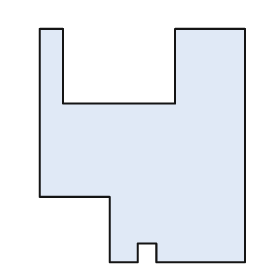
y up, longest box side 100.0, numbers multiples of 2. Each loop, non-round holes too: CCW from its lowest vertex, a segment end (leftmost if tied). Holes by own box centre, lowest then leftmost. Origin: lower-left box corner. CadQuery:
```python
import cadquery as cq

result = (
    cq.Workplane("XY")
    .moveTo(30.0, 0.0)
    .lineTo(42.0, 0.0)
    .lineTo(42.0, 8.0)
    .lineTo(50.0, 8.0)
    .lineTo(50.0, 0.0)
    .lineTo(88.0, 0.0)
    .lineTo(88.0, 100.0)
    .lineTo(58.0, 100.0)
    .lineTo(58.0, 68.0)
    .lineTo(10.0, 68.0)
    .lineTo(10.0, 100.0)
    .lineTo(0.0, 100.0)
    .lineTo(0.0, 28.0)
    .lineTo(30.0, 28.0)
    .close()
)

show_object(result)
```